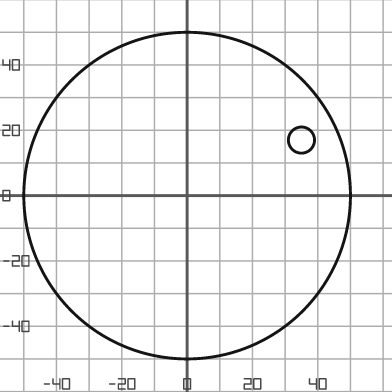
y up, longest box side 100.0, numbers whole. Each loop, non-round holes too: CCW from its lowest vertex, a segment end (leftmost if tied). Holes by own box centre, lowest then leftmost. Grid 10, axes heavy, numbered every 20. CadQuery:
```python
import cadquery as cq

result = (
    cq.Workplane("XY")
    .moveTo(0.0, 0.0)
    .circle(50.0)
    .moveTo(35.0, 17.0)
    .circle(4.0)
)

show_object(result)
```